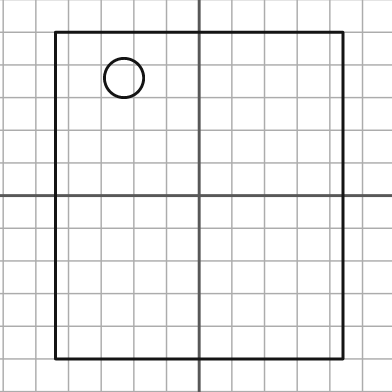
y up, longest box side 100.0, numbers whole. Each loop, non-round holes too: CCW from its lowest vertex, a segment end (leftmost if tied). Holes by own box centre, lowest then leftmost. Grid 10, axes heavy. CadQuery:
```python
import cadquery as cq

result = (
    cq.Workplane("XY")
    .moveTo(-44.0, -50.0)
    .lineTo(44.0, -50.0)
    .lineTo(44.0, 50.0)
    .lineTo(-44.0, 50.0)
    .close()
    .moveTo(-23.0, 36.0)
    .circle(6.0)
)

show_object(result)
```